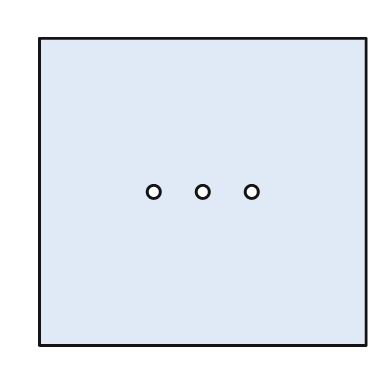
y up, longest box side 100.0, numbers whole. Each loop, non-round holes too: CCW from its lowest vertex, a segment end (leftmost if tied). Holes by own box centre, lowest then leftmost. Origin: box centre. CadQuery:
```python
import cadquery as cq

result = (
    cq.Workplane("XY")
    .moveTo(-50.0, -47.0)
    .lineTo(50.0, -47.0)
    .lineTo(50.0, 47.0)
    .lineTo(-50.0, 47.0)
    .close()
    .moveTo(-15.0, 0.0)
    .circle(2.0)
    .moveTo(0.0, 0.0)
    .circle(2.0)
    .moveTo(15.0, 0.0)
    .circle(2.0)
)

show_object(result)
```